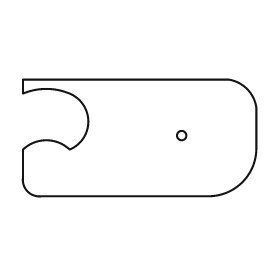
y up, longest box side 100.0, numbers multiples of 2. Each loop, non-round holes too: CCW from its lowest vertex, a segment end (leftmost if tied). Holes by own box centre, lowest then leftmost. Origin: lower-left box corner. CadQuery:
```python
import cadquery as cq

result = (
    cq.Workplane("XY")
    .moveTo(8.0, 0.0)
    .lineTo(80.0, 0.0)
    .threePointArc((94.0, 6.0), (100.0, 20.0))
    .lineTo(100.0, 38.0)
    .threePointArc((96.0, 46.0), (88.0, 50.0))
    .lineTo(0.0, 50.0)
    .lineTo(0.0, 44.0)
    .threePointArc((10.0, 46.0), (20.0, 44.0))
    .threePointArc((28.0, 32.0), (20.0, 20.0))
    .threePointArc((10.0, 24.0), (0.0, 20.0))
    .lineTo(0.0, 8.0)
    .threePointArc((2.0, 2.0), (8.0, 0.0))
    .close()
    .moveTo(68.0, 26.0)
    .circle(2.0)
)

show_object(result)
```